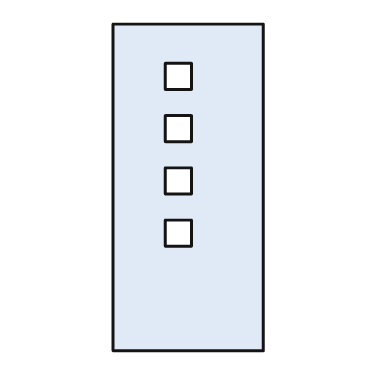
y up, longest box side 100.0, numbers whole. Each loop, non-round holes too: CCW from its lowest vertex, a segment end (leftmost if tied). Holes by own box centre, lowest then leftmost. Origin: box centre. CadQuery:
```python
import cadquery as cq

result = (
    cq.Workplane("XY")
    .moveTo(-23.0, -50.0)
    .lineTo(23.0, -50.0)
    .lineTo(23.0, 50.0)
    .lineTo(-23.0, 50.0)
    .close()
    .moveTo(-7.0, -18.0)
    .lineTo(1.0, -18.0)
    .lineTo(1.0, -10.0)
    .lineTo(-7.0, -10.0)
    .close()
    .moveTo(-7.0, -2.0)
    .lineTo(1.0, -2.0)
    .lineTo(1.0, 6.0)
    .lineTo(-7.0, 6.0)
    .close()
    .moveTo(-7.0, 14.0)
    .lineTo(1.0, 14.0)
    .lineTo(1.0, 22.0)
    .lineTo(-7.0, 22.0)
    .close()
    .moveTo(-7.0, 30.0)
    .lineTo(1.0, 30.0)
    .lineTo(1.0, 38.0)
    .lineTo(-7.0, 38.0)
    .close()
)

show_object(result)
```